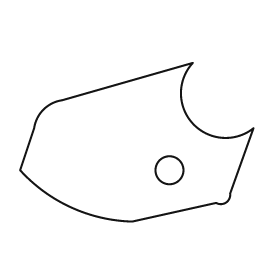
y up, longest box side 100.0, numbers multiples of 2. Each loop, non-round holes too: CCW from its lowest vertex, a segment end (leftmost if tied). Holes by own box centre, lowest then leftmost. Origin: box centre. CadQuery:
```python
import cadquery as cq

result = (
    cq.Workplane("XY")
    .moveTo(-2.0, -34.0)
    .lineTo(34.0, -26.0)
    .threePointArc((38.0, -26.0), (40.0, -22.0))
    .lineTo(50.0, 6.0)
    .threePointArc((24.0, 8.0), (24.0, 34.0))
    .lineTo(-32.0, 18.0)
    .threePointArc((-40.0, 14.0), (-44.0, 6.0))
    .lineTo(-50.0, -12.0)
    .threePointArc((-28.0, -28.0), (-2.0, -34.0))
    .close()
    .moveTo(14.0, -12.0)
    .circle(6.0)
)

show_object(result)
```